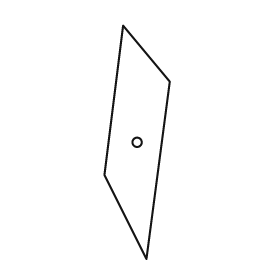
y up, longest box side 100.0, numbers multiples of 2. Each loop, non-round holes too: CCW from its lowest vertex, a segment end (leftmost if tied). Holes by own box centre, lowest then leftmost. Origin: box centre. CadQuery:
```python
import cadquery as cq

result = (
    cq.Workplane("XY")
    .moveTo(4.0, -50.0)
    .lineTo(14.0, 26.0)
    .lineTo(-6.0, 50.0)
    .lineTo(-14.0, -14.0)
    .close()
    .moveTo(0.0, 0.0)
    .circle(2.0)
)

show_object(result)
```